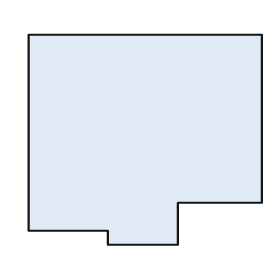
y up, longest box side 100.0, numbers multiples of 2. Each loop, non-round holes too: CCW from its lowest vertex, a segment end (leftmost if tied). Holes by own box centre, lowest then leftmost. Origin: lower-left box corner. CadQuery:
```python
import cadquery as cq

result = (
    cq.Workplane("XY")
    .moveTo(34.0, 0.0)
    .lineTo(64.0, 0.0)
    .lineTo(64.0, 18.0)
    .lineTo(100.0, 18.0)
    .lineTo(100.0, 90.0)
    .lineTo(0.0, 90.0)
    .lineTo(0.0, 6.0)
    .lineTo(34.0, 6.0)
    .close()
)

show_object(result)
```